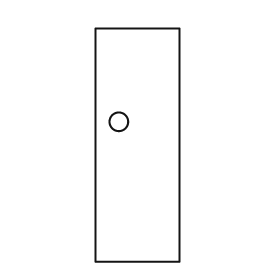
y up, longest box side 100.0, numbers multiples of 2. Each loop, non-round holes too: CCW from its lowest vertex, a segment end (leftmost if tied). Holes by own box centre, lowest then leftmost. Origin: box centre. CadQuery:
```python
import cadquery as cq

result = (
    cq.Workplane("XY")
    .moveTo(-18.0, -50.0)
    .lineTo(18.0, -50.0)
    .lineTo(18.0, 50.0)
    .lineTo(-18.0, 50.0)
    .close()
    .moveTo(-8.0, 10.0)
    .circle(4.0)
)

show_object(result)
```